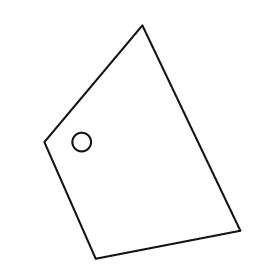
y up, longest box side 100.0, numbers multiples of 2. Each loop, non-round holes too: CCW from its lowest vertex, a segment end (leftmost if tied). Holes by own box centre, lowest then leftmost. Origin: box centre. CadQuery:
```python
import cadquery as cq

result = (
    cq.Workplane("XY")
    .moveTo(-20.0, -50.0)
    .lineTo(42.0, -38.0)
    .lineTo(0.0, 50.0)
    .lineTo(-42.0, 0.0)
    .close()
    .moveTo(-26.0, 0.0)
    .circle(4.0)
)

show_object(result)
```